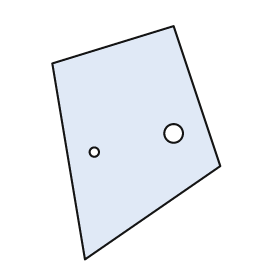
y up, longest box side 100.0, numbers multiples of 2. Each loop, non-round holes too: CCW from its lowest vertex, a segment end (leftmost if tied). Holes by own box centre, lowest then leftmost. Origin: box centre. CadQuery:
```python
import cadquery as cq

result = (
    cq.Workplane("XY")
    .moveTo(-22.0, -50.0)
    .lineTo(36.0, -10.0)
    .lineTo(16.0, 50.0)
    .lineTo(-36.0, 34.0)
    .close()
    .moveTo(-18.0, -4.0)
    .circle(2.0)
    .moveTo(16.0, 4.0)
    .circle(4.0)
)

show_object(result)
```